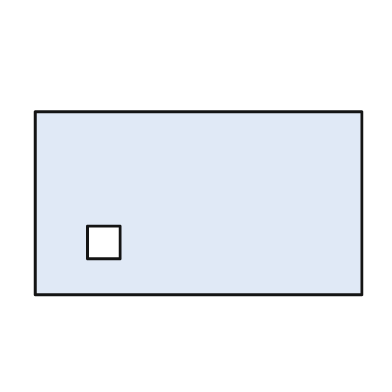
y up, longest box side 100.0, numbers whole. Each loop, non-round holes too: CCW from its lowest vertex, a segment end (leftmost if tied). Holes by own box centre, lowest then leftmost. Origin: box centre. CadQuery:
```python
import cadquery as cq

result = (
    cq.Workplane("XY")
    .moveTo(-50.0, -28.0)
    .lineTo(50.0, -28.0)
    .lineTo(50.0, 28.0)
    .lineTo(-50.0, 28.0)
    .close()
    .moveTo(-34.0, -17.0)
    .lineTo(-24.0, -17.0)
    .lineTo(-24.0, -7.0)
    .lineTo(-34.0, -7.0)
    .close()
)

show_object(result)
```